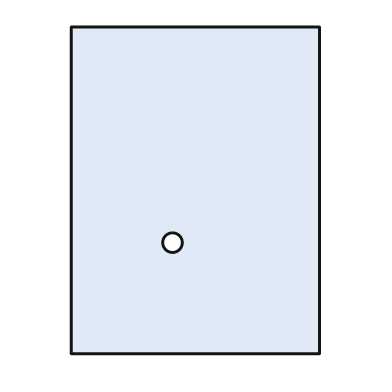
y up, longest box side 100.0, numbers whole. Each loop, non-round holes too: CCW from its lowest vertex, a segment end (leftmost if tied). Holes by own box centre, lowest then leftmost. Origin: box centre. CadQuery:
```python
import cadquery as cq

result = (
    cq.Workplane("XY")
    .moveTo(-38.0, -50.0)
    .lineTo(38.0, -50.0)
    .lineTo(38.0, 50.0)
    .lineTo(-38.0, 50.0)
    .close()
    .moveTo(-7.0, -16.0)
    .circle(3.0)
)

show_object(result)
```